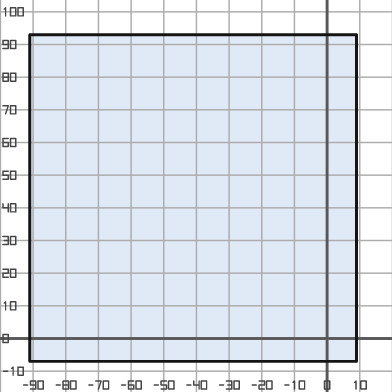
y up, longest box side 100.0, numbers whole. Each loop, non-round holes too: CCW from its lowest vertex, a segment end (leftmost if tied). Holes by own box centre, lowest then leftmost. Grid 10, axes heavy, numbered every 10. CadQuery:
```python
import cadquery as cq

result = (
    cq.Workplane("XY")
    .moveTo(-91.0, -7.0)
    .lineTo(9.0, -7.0)
    .lineTo(9.0, 93.0)
    .lineTo(-91.0, 93.0)
    .close()
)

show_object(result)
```